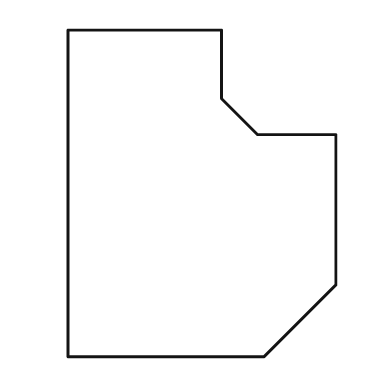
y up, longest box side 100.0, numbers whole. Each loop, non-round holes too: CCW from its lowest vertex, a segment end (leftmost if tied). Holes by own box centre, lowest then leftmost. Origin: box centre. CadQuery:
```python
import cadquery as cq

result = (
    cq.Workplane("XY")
    .moveTo(-41.0, -50.0)
    .lineTo(19.0, -50.0)
    .lineTo(41.0, -28.0)
    .lineTo(41.0, 18.0)
    .lineTo(17.0, 18.0)
    .lineTo(6.0, 29.0)
    .lineTo(6.0, 50.0)
    .lineTo(-41.0, 50.0)
    .close()
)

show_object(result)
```